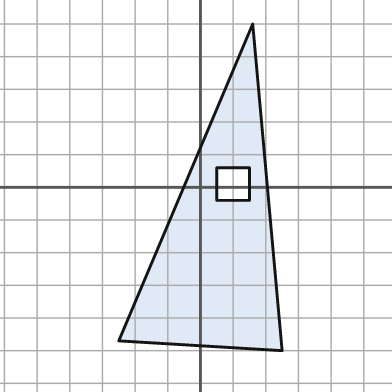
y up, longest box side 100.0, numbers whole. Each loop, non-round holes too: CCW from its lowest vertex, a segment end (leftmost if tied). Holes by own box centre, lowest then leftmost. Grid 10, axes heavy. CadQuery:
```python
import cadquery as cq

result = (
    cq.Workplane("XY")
    .moveTo(25.0, -50.0)
    .lineTo(16.0, 50.0)
    .lineTo(-25.0, -47.0)
    .close()
    .moveTo(5.0, -4.0)
    .lineTo(15.0, -4.0)
    .lineTo(15.0, 6.0)
    .lineTo(5.0, 6.0)
    .close()
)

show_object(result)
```